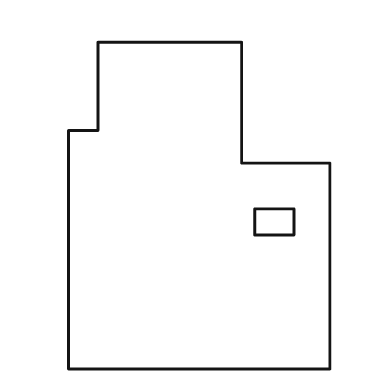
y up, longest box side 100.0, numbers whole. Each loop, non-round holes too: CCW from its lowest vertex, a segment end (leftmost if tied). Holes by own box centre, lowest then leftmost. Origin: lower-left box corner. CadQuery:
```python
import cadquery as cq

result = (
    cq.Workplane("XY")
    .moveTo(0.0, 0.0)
    .lineTo(80.0, 0.0)
    .lineTo(80.0, 63.0)
    .lineTo(53.0, 63.0)
    .lineTo(53.0, 100.0)
    .lineTo(9.0, 100.0)
    .lineTo(9.0, 73.0)
    .lineTo(0.0, 73.0)
    .close()
    .moveTo(57.0, 41.0)
    .lineTo(69.0, 41.0)
    .lineTo(69.0, 49.0)
    .lineTo(57.0, 49.0)
    .close()
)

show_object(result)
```